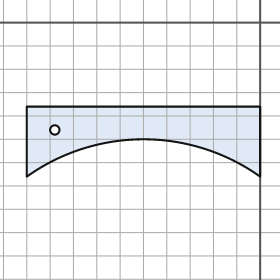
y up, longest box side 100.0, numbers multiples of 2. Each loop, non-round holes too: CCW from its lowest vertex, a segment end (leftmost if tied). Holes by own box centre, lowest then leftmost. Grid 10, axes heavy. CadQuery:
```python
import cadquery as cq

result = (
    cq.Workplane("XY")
    .moveTo(-100.0, -66.0)
    .threePointArc((-50.0, -50.0), (0.0, -66.0))
    .lineTo(0.0, -36.0)
    .lineTo(-100.0, -36.0)
    .close()
    .moveTo(-88.0, -46.0)
    .circle(2.0)
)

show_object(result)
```